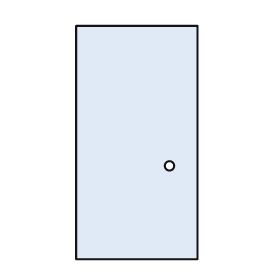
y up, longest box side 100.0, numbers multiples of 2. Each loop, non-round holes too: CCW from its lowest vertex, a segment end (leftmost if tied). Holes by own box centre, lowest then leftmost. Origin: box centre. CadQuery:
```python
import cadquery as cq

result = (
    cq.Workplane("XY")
    .moveTo(-26.0, -50.0)
    .lineTo(26.0, -50.0)
    .lineTo(26.0, 50.0)
    .lineTo(-26.0, 50.0)
    .close()
    .moveTo(14.0, -10.0)
    .circle(2.0)
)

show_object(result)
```